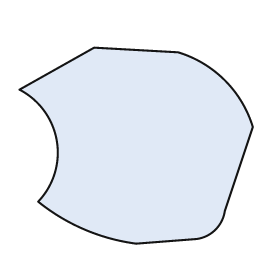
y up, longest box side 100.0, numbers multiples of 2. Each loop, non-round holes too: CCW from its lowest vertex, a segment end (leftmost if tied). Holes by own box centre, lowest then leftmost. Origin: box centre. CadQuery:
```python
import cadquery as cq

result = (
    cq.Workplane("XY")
    .moveTo(0.0, -42.0)
    .lineTo(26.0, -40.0)
    .threePointArc((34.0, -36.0), (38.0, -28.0))
    .lineTo(50.0, 8.0)
    .threePointArc((38.0, 28.0), (18.0, 40.0))
    .lineTo(-18.0, 42.0)
    .lineTo(-50.0, 24.0)
    .threePointArc((-34.0, 2.0), (-42.0, -24.0))
    .threePointArc((-22.0, -36.0), (0.0, -42.0))
    .close()
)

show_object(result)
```